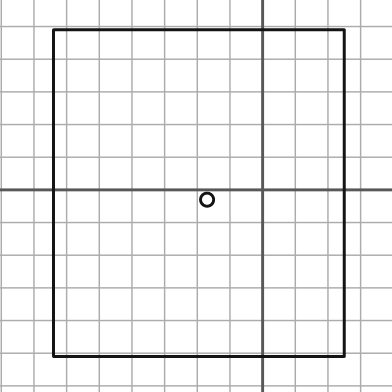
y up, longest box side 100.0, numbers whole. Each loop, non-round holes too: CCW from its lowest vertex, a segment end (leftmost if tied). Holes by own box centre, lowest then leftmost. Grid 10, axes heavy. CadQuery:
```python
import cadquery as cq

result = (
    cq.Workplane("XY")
    .moveTo(-64.0, -51.0)
    .lineTo(25.0, -51.0)
    .lineTo(25.0, 49.0)
    .lineTo(-64.0, 49.0)
    .close()
    .moveTo(-17.0, -3.0)
    .circle(2.0)
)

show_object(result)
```